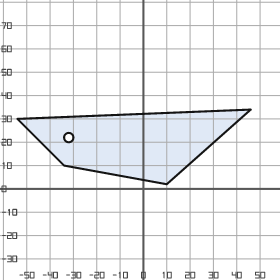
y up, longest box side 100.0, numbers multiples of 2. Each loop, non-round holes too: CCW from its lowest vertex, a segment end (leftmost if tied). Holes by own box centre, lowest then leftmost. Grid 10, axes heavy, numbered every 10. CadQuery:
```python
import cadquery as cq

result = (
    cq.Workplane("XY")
    .moveTo(10.0, 2.0)
    .lineTo(46.0, 34.0)
    .lineTo(-54.0, 30.0)
    .lineTo(-34.0, 10.0)
    .close()
    .moveTo(-32.0, 22.0)
    .circle(2.0)
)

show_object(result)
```